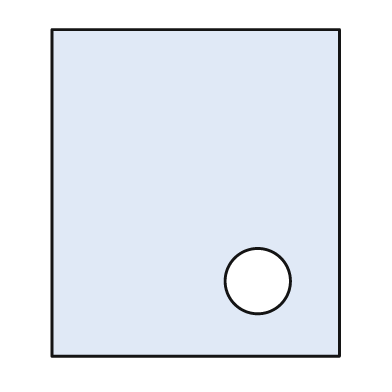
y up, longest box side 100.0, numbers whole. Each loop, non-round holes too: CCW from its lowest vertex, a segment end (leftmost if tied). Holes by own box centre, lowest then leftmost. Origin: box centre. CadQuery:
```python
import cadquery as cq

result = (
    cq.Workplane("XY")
    .moveTo(-44.0, -50.0)
    .lineTo(44.0, -50.0)
    .lineTo(44.0, 50.0)
    .lineTo(-44.0, 50.0)
    .close()
    .moveTo(19.0, -27.0)
    .circle(10.0)
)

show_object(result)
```